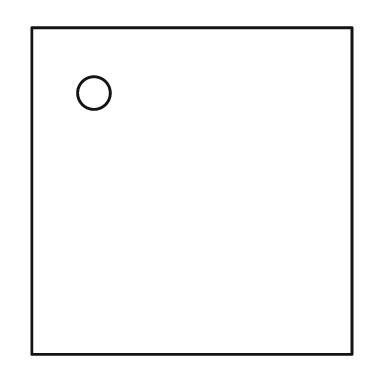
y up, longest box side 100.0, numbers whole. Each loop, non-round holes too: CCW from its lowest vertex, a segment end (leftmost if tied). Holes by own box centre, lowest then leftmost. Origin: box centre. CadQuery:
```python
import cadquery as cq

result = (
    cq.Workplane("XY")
    .moveTo(-49.0, -50.0)
    .lineTo(49.0, -50.0)
    .lineTo(49.0, 50.0)
    .lineTo(-49.0, 50.0)
    .close()
    .moveTo(-30.0, 30.0)
    .circle(5.0)
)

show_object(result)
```